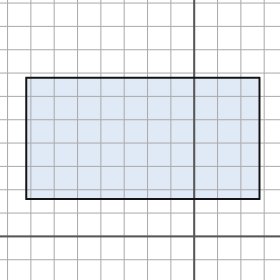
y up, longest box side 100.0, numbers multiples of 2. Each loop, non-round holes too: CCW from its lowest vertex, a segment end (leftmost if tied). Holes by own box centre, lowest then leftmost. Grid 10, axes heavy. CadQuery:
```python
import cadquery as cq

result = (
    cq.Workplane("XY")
    .moveTo(-72.0, 16.0)
    .lineTo(28.0, 16.0)
    .lineTo(28.0, 68.0)
    .lineTo(-72.0, 68.0)
    .close()
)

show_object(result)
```